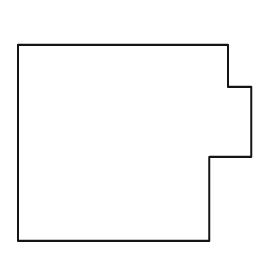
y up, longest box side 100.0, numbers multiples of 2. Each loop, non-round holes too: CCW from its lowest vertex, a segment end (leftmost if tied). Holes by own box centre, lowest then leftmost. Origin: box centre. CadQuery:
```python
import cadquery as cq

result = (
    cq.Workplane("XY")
    .moveTo(-50.0, -42.0)
    .lineTo(32.0, -42.0)
    .lineTo(32.0, -6.0)
    .lineTo(50.0, -6.0)
    .lineTo(50.0, 24.0)
    .lineTo(40.0, 24.0)
    .lineTo(40.0, 42.0)
    .lineTo(-50.0, 42.0)
    .close()
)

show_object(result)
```